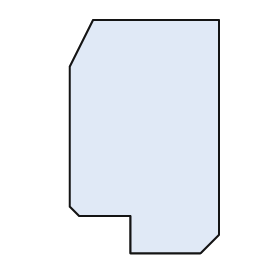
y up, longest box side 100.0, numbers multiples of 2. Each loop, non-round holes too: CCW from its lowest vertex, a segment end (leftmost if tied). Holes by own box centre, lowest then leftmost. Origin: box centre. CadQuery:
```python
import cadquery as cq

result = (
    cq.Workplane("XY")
    .moveTo(-6.0, -50.0)
    .lineTo(24.0, -50.0)
    .lineTo(32.0, -42.0)
    .lineTo(32.0, 50.0)
    .lineTo(-22.0, 50.0)
    .lineTo(-32.0, 30.0)
    .lineTo(-32.0, -30.0)
    .lineTo(-28.0, -34.0)
    .lineTo(-6.0, -34.0)
    .close()
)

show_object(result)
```